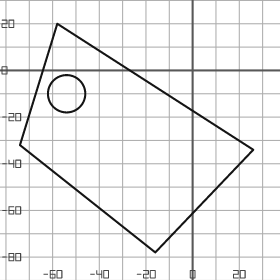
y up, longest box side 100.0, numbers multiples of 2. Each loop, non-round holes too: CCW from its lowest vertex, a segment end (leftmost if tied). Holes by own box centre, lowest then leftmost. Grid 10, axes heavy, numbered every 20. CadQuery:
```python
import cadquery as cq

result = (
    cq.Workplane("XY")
    .moveTo(-16.0, -78.0)
    .lineTo(26.0, -34.0)
    .lineTo(-58.0, 20.0)
    .lineTo(-74.0, -32.0)
    .close()
    .moveTo(-54.0, -10.0)
    .circle(8.0)
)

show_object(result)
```